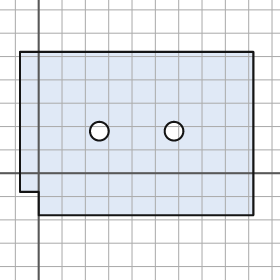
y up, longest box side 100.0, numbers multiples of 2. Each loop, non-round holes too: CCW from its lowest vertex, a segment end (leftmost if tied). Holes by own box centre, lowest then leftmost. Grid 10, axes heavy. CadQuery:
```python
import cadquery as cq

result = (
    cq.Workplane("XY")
    .moveTo(0.0, -18.0)
    .lineTo(92.0, -18.0)
    .lineTo(92.0, 52.0)
    .lineTo(-8.0, 52.0)
    .lineTo(-8.0, -8.0)
    .lineTo(0.0, -8.0)
    .close()
    .moveTo(26.0, 18.0)
    .circle(4.0)
    .moveTo(58.0, 18.0)
    .circle(4.0)
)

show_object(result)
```